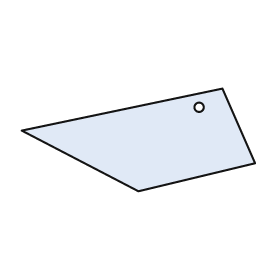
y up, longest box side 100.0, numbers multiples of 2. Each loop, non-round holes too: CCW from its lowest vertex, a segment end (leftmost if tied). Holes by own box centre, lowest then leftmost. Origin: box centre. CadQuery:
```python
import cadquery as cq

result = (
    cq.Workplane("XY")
    .moveTo(0.0, -22.0)
    .lineTo(50.0, -10.0)
    .lineTo(36.0, 22.0)
    .lineTo(-50.0, 4.0)
    .close()
    .moveTo(26.0, 14.0)
    .circle(2.0)
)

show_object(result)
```